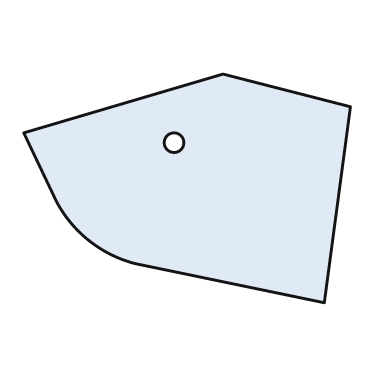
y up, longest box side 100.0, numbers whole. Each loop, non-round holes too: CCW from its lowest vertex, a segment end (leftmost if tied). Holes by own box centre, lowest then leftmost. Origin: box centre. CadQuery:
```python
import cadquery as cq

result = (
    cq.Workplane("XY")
    .moveTo(42.0, -35.0)
    .lineTo(50.0, 25.0)
    .lineTo(11.0, 35.0)
    .lineTo(-50.0, 17.0)
    .lineTo(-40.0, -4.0)
    .threePointArc((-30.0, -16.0), (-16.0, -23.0))
    .close()
    .moveTo(-4.0, 14.0)
    .circle(3.0)
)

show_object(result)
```